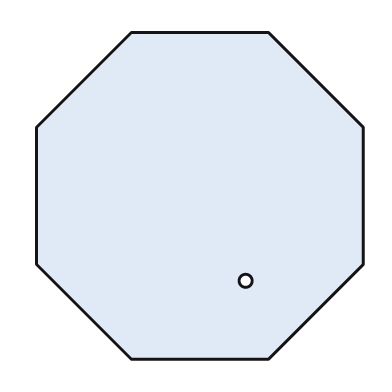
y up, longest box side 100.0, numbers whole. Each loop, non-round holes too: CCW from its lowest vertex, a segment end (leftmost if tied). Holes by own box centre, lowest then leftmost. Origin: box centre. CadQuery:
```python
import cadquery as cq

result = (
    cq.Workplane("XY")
    .moveTo(-21.0, -50.0)
    .lineTo(21.0, -50.0)
    .lineTo(50.0, -21.0)
    .lineTo(50.0, 21.0)
    .lineTo(21.0, 50.0)
    .lineTo(-21.0, 50.0)
    .lineTo(-50.0, 21.0)
    .lineTo(-50.0, -21.0)
    .close()
    .moveTo(14.0, -26.0)
    .circle(2.0)
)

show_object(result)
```